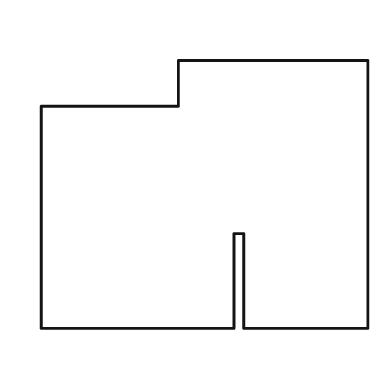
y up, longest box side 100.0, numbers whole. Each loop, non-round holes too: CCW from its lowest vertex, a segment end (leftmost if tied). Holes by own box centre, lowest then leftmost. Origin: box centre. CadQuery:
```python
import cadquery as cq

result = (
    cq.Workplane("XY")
    .moveTo(-50.0, -41.0)
    .lineTo(9.0, -41.0)
    .lineTo(9.0, -12.0)
    .lineTo(12.0, -12.0)
    .lineTo(12.0, -41.0)
    .lineTo(50.0, -41.0)
    .lineTo(50.0, 41.0)
    .lineTo(-8.0, 41.0)
    .lineTo(-8.0, 27.0)
    .lineTo(-50.0, 27.0)
    .close()
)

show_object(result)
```